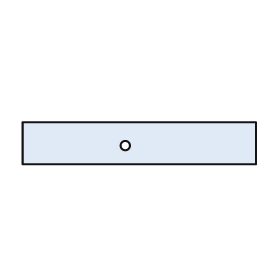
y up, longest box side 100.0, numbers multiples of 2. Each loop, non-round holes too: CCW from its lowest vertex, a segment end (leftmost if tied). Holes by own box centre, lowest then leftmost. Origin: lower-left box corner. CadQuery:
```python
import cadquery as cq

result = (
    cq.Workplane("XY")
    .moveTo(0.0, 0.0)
    .lineTo(100.0, 0.0)
    .lineTo(100.0, 18.0)
    .lineTo(0.0, 18.0)
    .close()
    .moveTo(44.0, 8.0)
    .circle(2.0)
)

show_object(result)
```